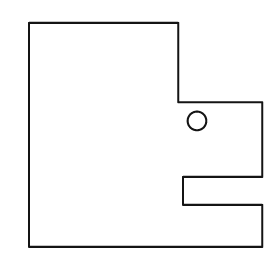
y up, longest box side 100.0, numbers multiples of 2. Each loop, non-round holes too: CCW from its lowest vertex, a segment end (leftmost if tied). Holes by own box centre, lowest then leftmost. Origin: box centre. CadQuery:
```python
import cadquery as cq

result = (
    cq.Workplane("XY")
    .moveTo(-50.0, -48.0)
    .lineTo(50.0, -48.0)
    .lineTo(50.0, -30.0)
    .lineTo(16.0, -30.0)
    .lineTo(16.0, -18.0)
    .lineTo(50.0, -18.0)
    .lineTo(50.0, 14.0)
    .lineTo(14.0, 14.0)
    .lineTo(14.0, 48.0)
    .lineTo(-50.0, 48.0)
    .close()
    .moveTo(22.0, 6.0)
    .circle(4.0)
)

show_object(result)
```